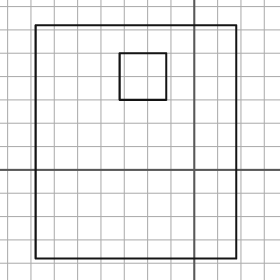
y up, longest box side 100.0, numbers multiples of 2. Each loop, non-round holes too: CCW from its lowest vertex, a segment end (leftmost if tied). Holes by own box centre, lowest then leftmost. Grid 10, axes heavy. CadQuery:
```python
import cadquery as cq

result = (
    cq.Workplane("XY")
    .moveTo(-68.0, -38.0)
    .lineTo(18.0, -38.0)
    .lineTo(18.0, 62.0)
    .lineTo(-68.0, 62.0)
    .close()
    .moveTo(-32.0, 30.0)
    .lineTo(-12.0, 30.0)
    .lineTo(-12.0, 50.0)
    .lineTo(-32.0, 50.0)
    .close()
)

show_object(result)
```